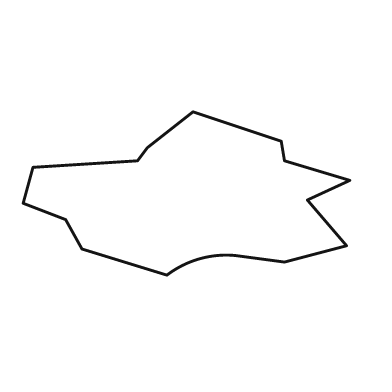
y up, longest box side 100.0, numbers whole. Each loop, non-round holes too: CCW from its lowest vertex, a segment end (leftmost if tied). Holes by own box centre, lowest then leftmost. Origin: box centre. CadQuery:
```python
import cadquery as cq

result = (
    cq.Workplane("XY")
    .moveTo(-6.0, -25.0)
    .threePointArc((4.0, -20.0), (15.0, -19.0))
    .lineTo(30.0, -21.0)
    .lineTo(49.0, -16.0)
    .lineTo(37.0, -2.0)
    .lineTo(50.0, 4.0)
    .lineTo(30.0, 10.0)
    .lineTo(29.0, 16.0)
    .lineTo(2.0, 25.0)
    .lineTo(-12.0, 14.0)
    .lineTo(-15.0, 10.0)
    .lineTo(-47.0, 8.0)
    .lineTo(-50.0, -3.0)
    .lineTo(-37.0, -8.0)
    .lineTo(-32.0, -17.0)
    .close()
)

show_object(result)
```